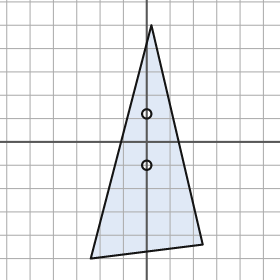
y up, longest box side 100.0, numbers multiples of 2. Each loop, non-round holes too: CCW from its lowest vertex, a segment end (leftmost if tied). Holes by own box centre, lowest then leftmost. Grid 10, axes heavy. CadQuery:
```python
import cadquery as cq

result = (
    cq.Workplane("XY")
    .moveTo(-24.0, -50.0)
    .lineTo(24.0, -44.0)
    .lineTo(2.0, 50.0)
    .close()
    .moveTo(0.0, -10.0)
    .circle(2.0)
    .moveTo(0.0, 12.0)
    .circle(2.0)
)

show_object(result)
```